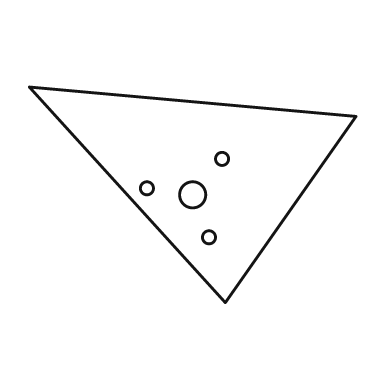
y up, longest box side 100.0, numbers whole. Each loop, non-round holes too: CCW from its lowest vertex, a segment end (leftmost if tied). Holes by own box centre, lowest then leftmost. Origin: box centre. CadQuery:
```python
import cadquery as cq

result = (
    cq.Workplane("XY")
    .moveTo(10.0, -33.0)
    .lineTo(50.0, 24.0)
    .lineTo(-50.0, 33.0)
    .close()
    .moveTo(5.0, -13.0)
    .circle(2.0)
    .moveTo(0.0, 0.0)
    .circle(4.0)
    .moveTo(-14.0, 2.0)
    .circle(2.0)
    .moveTo(9.0, 11.0)
    .circle(2.0)
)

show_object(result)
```